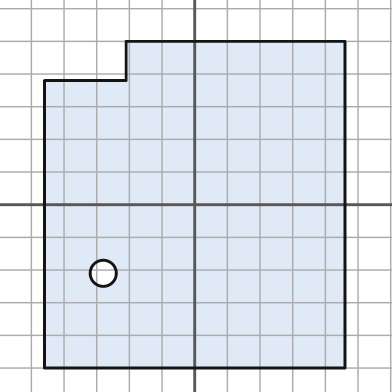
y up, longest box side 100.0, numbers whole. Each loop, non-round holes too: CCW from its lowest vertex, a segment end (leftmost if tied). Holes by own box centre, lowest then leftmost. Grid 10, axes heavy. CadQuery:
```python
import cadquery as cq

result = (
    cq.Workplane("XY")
    .moveTo(-46.0, -50.0)
    .lineTo(46.0, -50.0)
    .lineTo(46.0, 50.0)
    .lineTo(-21.0, 50.0)
    .lineTo(-21.0, 38.0)
    .lineTo(-46.0, 38.0)
    .close()
    .moveTo(-28.0, -21.0)
    .circle(4.0)
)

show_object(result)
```